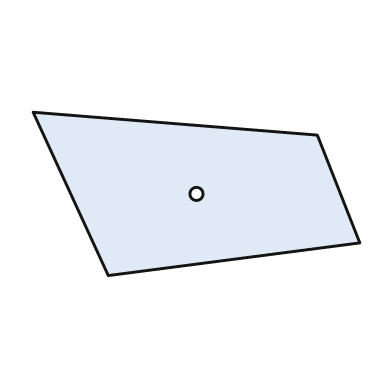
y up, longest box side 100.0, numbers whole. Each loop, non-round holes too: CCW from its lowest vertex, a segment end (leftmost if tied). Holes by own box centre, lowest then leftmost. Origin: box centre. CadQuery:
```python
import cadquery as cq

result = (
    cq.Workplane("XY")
    .moveTo(-27.0, -25.0)
    .lineTo(50.0, -15.0)
    .lineTo(37.0, 18.0)
    .lineTo(-50.0, 25.0)
    .close()
    .moveTo(0.0, 0.0)
    .circle(2.0)
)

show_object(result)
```